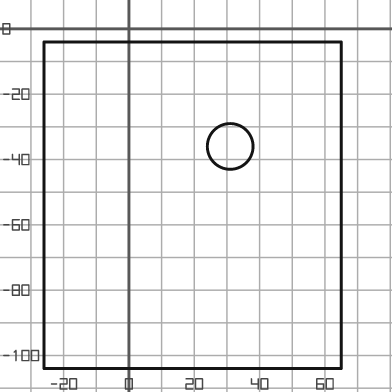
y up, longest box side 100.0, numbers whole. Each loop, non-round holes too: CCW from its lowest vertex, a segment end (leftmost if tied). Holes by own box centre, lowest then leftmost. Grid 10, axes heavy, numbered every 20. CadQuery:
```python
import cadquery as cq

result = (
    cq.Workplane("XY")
    .moveTo(-26.0, -104.0)
    .lineTo(65.0, -104.0)
    .lineTo(65.0, -4.0)
    .lineTo(-26.0, -4.0)
    .close()
    .moveTo(31.0, -36.0)
    .circle(7.0)
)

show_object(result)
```